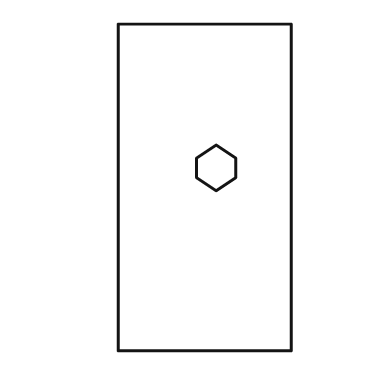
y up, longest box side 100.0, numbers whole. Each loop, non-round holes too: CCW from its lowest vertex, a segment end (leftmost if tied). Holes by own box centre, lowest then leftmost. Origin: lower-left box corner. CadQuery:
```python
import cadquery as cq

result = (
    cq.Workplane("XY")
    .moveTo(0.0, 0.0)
    .lineTo(53.0, 0.0)
    .lineTo(53.0, 100.0)
    .lineTo(0.0, 100.0)
    .close()
    .moveTo(30.0, 49.0)
    .lineTo(36.0, 53.0)
    .lineTo(36.0, 59.0)
    .lineTo(30.0, 63.0)
    .lineTo(24.0, 59.0)
    .lineTo(24.0, 53.0)
    .close()
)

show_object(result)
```